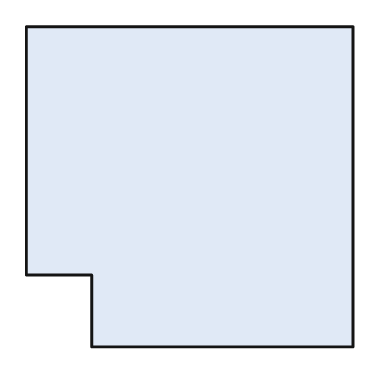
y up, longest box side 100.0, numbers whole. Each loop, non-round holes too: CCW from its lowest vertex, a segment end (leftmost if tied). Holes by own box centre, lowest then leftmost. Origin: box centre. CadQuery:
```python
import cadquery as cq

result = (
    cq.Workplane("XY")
    .moveTo(-30.0, -49.0)
    .lineTo(50.0, -49.0)
    .lineTo(50.0, 49.0)
    .lineTo(-50.0, 49.0)
    .lineTo(-50.0, -27.0)
    .lineTo(-30.0, -27.0)
    .close()
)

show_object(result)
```